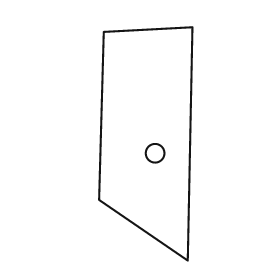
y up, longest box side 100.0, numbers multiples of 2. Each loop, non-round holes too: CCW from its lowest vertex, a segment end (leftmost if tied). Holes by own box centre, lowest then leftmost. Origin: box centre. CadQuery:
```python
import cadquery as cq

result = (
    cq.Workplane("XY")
    .moveTo(18.0, -50.0)
    .lineTo(20.0, 50.0)
    .lineTo(-18.0, 48.0)
    .lineTo(-20.0, -24.0)
    .close()
    .moveTo(4.0, -4.0)
    .circle(4.0)
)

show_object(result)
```